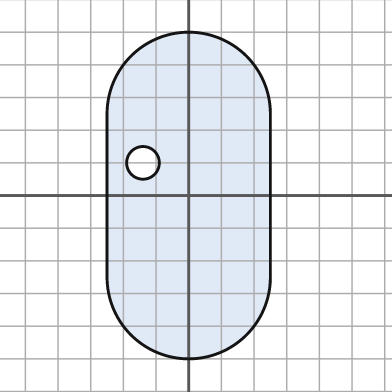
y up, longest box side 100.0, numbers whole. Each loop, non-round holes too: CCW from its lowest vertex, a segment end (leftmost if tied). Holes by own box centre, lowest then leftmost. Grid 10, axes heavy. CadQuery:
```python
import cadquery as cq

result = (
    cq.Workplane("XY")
    .moveTo(-25.0, -25.0)
    .threePointArc((0.0, -50.0), (25.0, -25.0))
    .lineTo(25.0, 25.0)
    .threePointArc((0.0, 50.0), (-25.0, 25.0))
    .close()
    .moveTo(-14.0, 10.0)
    .circle(5.0)
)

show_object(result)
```